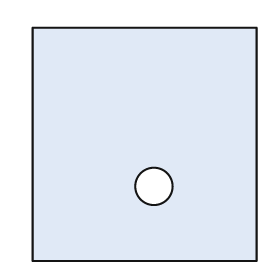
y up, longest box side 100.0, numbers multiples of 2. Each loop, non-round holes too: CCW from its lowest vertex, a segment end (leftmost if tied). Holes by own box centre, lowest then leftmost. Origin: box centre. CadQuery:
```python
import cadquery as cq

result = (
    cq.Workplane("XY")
    .moveTo(-48.0, -50.0)
    .lineTo(48.0, -50.0)
    .lineTo(48.0, 50.0)
    .lineTo(-48.0, 50.0)
    .close()
    .moveTo(4.0, -18.0)
    .circle(8.0)
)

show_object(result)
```